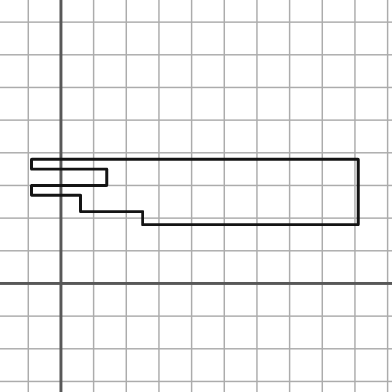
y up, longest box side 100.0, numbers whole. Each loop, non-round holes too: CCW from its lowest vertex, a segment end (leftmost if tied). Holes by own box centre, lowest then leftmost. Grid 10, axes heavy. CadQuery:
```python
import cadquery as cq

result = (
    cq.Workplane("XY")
    .moveTo(25.0, 18.0)
    .lineTo(91.0, 18.0)
    .lineTo(91.0, 38.0)
    .lineTo(-9.0, 38.0)
    .lineTo(-9.0, 35.0)
    .lineTo(14.0, 35.0)
    .lineTo(14.0, 30.0)
    .lineTo(-9.0, 30.0)
    .lineTo(-9.0, 27.0)
    .lineTo(6.0, 27.0)
    .lineTo(6.0, 22.0)
    .lineTo(25.0, 22.0)
    .close()
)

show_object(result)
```